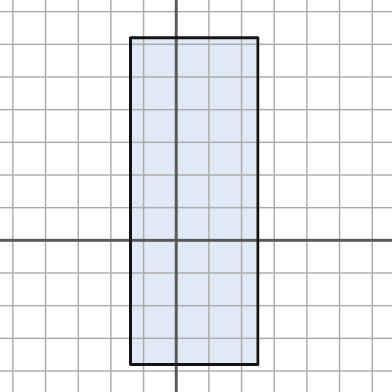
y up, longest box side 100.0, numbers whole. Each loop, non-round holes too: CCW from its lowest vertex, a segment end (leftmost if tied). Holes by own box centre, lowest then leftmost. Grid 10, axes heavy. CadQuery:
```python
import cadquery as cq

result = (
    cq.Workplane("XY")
    .moveTo(-14.0, -38.0)
    .lineTo(25.0, -38.0)
    .lineTo(25.0, 62.0)
    .lineTo(-14.0, 62.0)
    .close()
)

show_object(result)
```